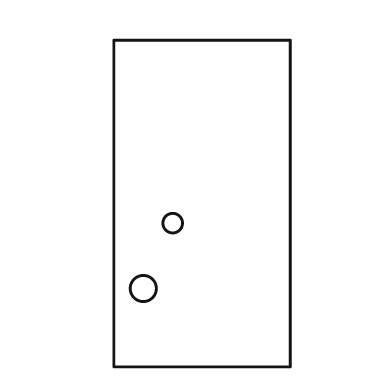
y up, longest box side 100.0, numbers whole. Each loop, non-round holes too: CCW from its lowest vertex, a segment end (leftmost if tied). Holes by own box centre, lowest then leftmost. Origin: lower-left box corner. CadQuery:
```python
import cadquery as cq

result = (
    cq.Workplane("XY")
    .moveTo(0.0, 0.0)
    .lineTo(54.0, 0.0)
    .lineTo(54.0, 100.0)
    .lineTo(0.0, 100.0)
    .close()
    .moveTo(9.0, 24.0)
    .circle(4.0)
    .moveTo(18.0, 44.0)
    .circle(3.0)
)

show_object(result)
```